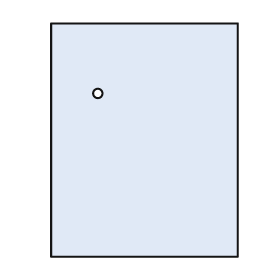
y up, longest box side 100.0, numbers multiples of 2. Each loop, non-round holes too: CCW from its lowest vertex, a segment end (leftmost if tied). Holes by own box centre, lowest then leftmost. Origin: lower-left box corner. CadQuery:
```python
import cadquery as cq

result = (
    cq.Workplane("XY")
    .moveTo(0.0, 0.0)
    .lineTo(80.0, 0.0)
    .lineTo(80.0, 100.0)
    .lineTo(0.0, 100.0)
    .close()
    .moveTo(20.0, 70.0)
    .circle(2.0)
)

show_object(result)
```